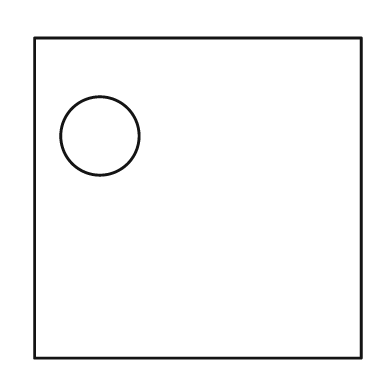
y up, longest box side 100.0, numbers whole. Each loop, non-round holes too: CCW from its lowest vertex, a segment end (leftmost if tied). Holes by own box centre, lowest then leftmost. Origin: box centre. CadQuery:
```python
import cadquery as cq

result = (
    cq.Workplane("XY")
    .moveTo(-50.0, -49.0)
    .lineTo(50.0, -49.0)
    .lineTo(50.0, 49.0)
    .lineTo(-50.0, 49.0)
    .close()
    .moveTo(-30.0, 19.0)
    .circle(12.0)
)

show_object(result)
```